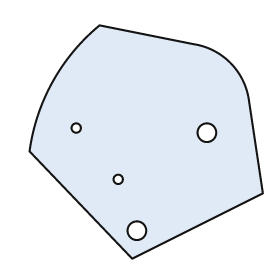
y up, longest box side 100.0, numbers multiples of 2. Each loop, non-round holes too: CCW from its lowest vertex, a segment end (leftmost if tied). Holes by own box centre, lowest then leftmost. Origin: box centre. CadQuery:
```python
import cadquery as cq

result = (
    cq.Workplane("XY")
    .moveTo(-6.0, -50.0)
    .lineTo(50.0, -22.0)
    .lineTo(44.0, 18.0)
    .threePointArc((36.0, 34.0), (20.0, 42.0))
    .lineTo(-20.0, 50.0)
    .threePointArc((-40.0, 26.0), (-50.0, -4.0))
    .close()
    .moveTo(-4.0, -38.0)
    .circle(4.0)
    .moveTo(-12.0, -16.0)
    .circle(2.0)
    .moveTo(26.0, 4.0)
    .circle(4.0)
    .moveTo(-30.0, 6.0)
    .circle(2.0)
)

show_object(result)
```